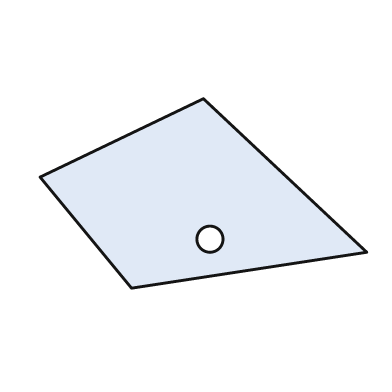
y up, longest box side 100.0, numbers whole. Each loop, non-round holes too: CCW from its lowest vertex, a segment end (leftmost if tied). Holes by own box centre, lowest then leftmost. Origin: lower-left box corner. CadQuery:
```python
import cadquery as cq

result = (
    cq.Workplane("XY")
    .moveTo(28.0, 0.0)
    .lineTo(100.0, 11.0)
    .lineTo(50.0, 58.0)
    .lineTo(0.0, 34.0)
    .close()
    .moveTo(52.0, 15.0)
    .circle(4.0)
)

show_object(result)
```